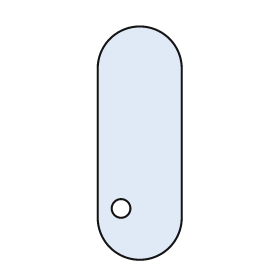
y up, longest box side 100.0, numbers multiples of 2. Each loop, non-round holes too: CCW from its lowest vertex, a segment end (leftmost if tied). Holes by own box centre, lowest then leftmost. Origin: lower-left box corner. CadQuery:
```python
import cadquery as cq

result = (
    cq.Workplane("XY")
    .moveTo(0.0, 18.0)
    .threePointArc((18.0, 0.0), (36.0, 18.0))
    .lineTo(36.0, 82.0)
    .threePointArc((18.0, 100.0), (0.0, 82.0))
    .close()
    .moveTo(10.0, 22.0)
    .circle(4.0)
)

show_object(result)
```